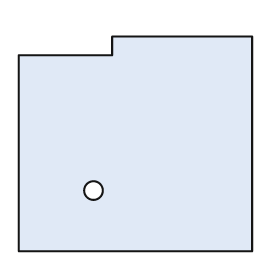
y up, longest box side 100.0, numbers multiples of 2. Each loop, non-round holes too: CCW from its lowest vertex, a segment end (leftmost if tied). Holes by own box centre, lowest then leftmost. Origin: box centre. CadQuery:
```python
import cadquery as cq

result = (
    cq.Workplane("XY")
    .moveTo(-50.0, -46.0)
    .lineTo(50.0, -46.0)
    .lineTo(50.0, 46.0)
    .lineTo(-10.0, 46.0)
    .lineTo(-10.0, 38.0)
    .lineTo(-50.0, 38.0)
    .close()
    .moveTo(-18.0, -20.0)
    .circle(4.0)
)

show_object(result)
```